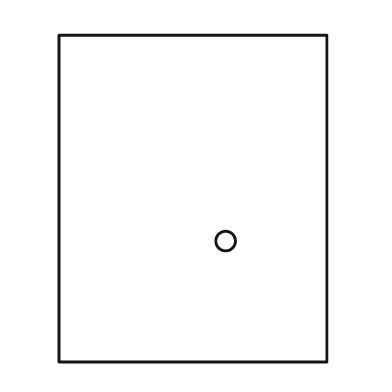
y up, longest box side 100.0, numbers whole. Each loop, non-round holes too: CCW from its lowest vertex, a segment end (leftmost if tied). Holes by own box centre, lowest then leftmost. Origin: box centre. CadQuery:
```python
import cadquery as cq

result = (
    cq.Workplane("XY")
    .moveTo(-41.0, -50.0)
    .lineTo(41.0, -50.0)
    .lineTo(41.0, 50.0)
    .lineTo(-41.0, 50.0)
    .close()
    .moveTo(10.0, -13.0)
    .circle(3.0)
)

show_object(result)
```